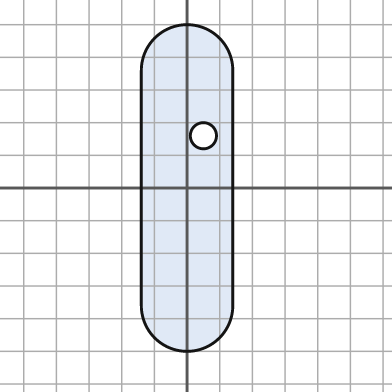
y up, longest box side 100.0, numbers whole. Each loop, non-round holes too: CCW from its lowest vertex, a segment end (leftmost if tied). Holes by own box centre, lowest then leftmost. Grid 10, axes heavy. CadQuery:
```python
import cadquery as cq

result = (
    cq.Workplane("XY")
    .moveTo(-14.0, -36.0)
    .threePointArc((0.0, -50.0), (14.0, -36.0))
    .lineTo(14.0, 36.0)
    .threePointArc((0.0, 50.0), (-14.0, 36.0))
    .close()
    .moveTo(5.0, 16.0)
    .circle(4.0)
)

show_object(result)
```